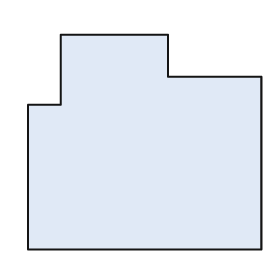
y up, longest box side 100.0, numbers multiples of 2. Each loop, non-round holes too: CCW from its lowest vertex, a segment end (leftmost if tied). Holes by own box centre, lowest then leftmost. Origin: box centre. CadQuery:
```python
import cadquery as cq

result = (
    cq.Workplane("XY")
    .moveTo(-50.0, -46.0)
    .lineTo(50.0, -46.0)
    .lineTo(50.0, 28.0)
    .lineTo(10.0, 28.0)
    .lineTo(10.0, 46.0)
    .lineTo(-36.0, 46.0)
    .lineTo(-36.0, 16.0)
    .lineTo(-50.0, 16.0)
    .close()
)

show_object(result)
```